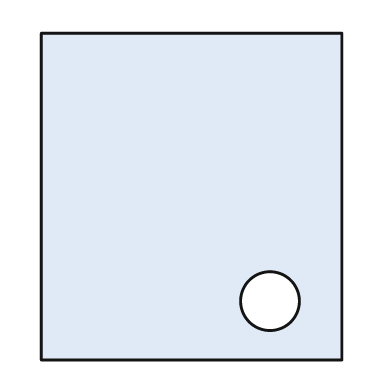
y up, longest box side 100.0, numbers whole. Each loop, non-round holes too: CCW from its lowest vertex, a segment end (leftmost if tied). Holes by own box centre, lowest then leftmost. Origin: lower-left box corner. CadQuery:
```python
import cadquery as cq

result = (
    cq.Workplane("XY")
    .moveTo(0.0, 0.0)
    .lineTo(92.0, 0.0)
    .lineTo(92.0, 100.0)
    .lineTo(0.0, 100.0)
    .close()
    .moveTo(70.0, 18.0)
    .circle(9.0)
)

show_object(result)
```